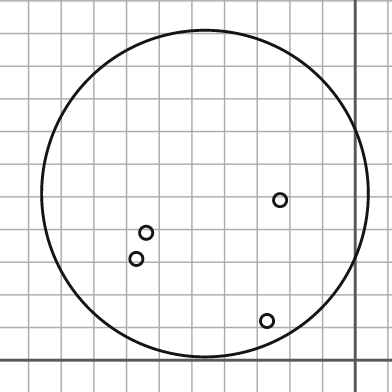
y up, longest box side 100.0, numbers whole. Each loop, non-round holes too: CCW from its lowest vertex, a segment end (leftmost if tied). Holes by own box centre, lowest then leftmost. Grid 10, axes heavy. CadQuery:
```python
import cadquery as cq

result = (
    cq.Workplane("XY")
    .moveTo(-46.0, 51.0)
    .circle(50.0)
    .moveTo(-27.0, 12.0)
    .circle(2.0)
    .moveTo(-67.0, 31.0)
    .circle(2.0)
    .moveTo(-64.0, 39.0)
    .circle(2.0)
    .moveTo(-23.0, 49.0)
    .circle(2.0)
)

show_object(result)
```